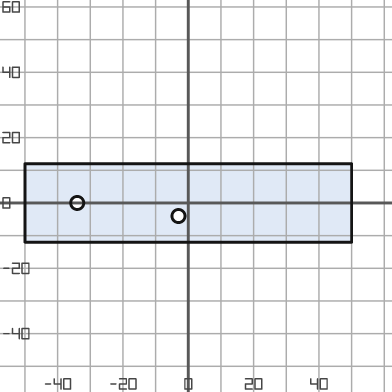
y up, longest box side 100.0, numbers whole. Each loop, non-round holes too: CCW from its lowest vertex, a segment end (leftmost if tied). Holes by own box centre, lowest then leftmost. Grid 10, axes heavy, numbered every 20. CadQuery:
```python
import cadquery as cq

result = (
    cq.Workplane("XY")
    .moveTo(-50.0, -12.0)
    .lineTo(50.0, -12.0)
    .lineTo(50.0, 12.0)
    .lineTo(-50.0, 12.0)
    .close()
    .moveTo(-3.0, -4.0)
    .circle(2.0)
    .moveTo(-34.0, 0.0)
    .circle(2.0)
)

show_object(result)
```